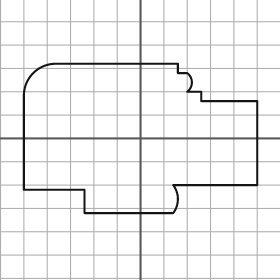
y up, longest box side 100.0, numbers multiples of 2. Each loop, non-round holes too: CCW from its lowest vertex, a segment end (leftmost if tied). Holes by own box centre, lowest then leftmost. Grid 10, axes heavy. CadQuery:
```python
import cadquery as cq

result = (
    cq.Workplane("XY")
    .moveTo(-24.0, -32.0)
    .lineTo(14.0, -32.0)
    .threePointArc((16.0, -26.0), (14.0, -20.0))
    .lineTo(50.0, -20.0)
    .lineTo(50.0, 16.0)
    .lineTo(26.0, 16.0)
    .lineTo(26.0, 20.0)
    .lineTo(20.0, 20.0)
    .threePointArc((22.0, 24.0), (20.0, 28.0))
    .lineTo(16.0, 28.0)
    .lineTo(16.0, 32.0)
    .lineTo(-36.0, 32.0)
    .threePointArc((-46.0, 28.0), (-50.0, 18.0))
    .lineTo(-50.0, -22.0)
    .lineTo(-24.0, -22.0)
    .close()
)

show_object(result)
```